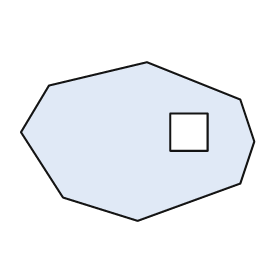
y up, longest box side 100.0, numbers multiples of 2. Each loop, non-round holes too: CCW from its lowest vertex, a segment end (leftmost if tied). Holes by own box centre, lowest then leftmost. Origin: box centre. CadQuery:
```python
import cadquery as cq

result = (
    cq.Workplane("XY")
    .moveTo(0.0, -34.0)
    .lineTo(44.0, -18.0)
    .lineTo(50.0, 0.0)
    .lineTo(44.0, 18.0)
    .lineTo(4.0, 34.0)
    .lineTo(-38.0, 24.0)
    .lineTo(-50.0, 4.0)
    .lineTo(-32.0, -24.0)
    .close()
    .moveTo(14.0, -4.0)
    .lineTo(30.0, -4.0)
    .lineTo(30.0, 12.0)
    .lineTo(14.0, 12.0)
    .close()
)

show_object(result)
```